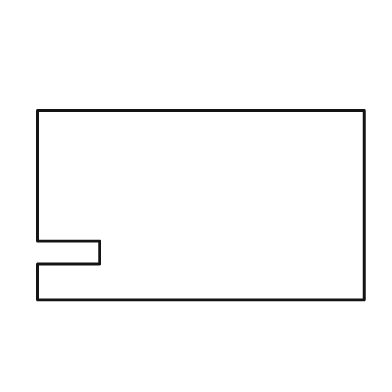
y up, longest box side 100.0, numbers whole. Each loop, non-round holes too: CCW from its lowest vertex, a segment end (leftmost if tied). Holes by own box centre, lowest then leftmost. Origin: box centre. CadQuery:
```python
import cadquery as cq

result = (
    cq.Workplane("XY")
    .moveTo(-50.0, -29.0)
    .lineTo(50.0, -29.0)
    .lineTo(50.0, 29.0)
    .lineTo(-50.0, 29.0)
    .lineTo(-50.0, -11.0)
    .lineTo(-31.0, -11.0)
    .lineTo(-31.0, -18.0)
    .lineTo(-50.0, -18.0)
    .close()
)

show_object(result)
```